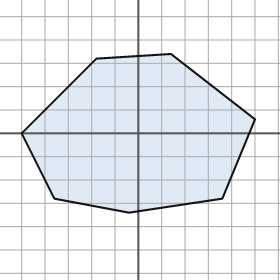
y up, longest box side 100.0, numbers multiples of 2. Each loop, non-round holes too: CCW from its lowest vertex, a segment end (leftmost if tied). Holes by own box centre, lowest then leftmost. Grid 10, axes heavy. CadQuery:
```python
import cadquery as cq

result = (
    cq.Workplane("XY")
    .moveTo(-4.0, -34.0)
    .lineTo(36.0, -28.0)
    .lineTo(50.0, 6.0)
    .lineTo(14.0, 34.0)
    .lineTo(-18.0, 32.0)
    .lineTo(-50.0, 0.0)
    .lineTo(-36.0, -28.0)
    .close()
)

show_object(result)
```